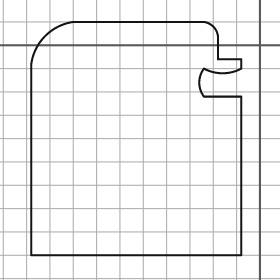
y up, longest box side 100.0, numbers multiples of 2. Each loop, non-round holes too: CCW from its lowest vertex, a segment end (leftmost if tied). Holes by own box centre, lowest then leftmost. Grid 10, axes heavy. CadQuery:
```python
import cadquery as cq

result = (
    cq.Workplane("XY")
    .moveTo(-98.0, -90.0)
    .lineTo(-8.0, -90.0)
    .lineTo(-8.0, -22.0)
    .lineTo(-24.0, -22.0)
    .threePointArc((-26.0, -16.0), (-24.0, -10.0))
    .threePointArc((-16.0, -12.0), (-8.0, -10.0))
    .lineTo(-8.0, -6.0)
    .lineTo(-18.0, -6.0)
    .lineTo(-18.0, 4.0)
    .threePointArc((-20.0, 8.0), (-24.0, 10.0))
    .lineTo(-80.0, 10.0)
    .threePointArc((-92.0, 4.0), (-98.0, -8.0))
    .close()
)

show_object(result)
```